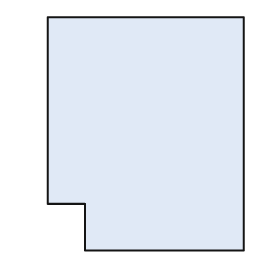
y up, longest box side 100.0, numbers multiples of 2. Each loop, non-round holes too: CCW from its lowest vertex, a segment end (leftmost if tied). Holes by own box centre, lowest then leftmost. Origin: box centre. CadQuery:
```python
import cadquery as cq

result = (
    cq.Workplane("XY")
    .moveTo(-26.0, -50.0)
    .lineTo(42.0, -50.0)
    .lineTo(42.0, 50.0)
    .lineTo(-42.0, 50.0)
    .lineTo(-42.0, -30.0)
    .lineTo(-26.0, -30.0)
    .close()
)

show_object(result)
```